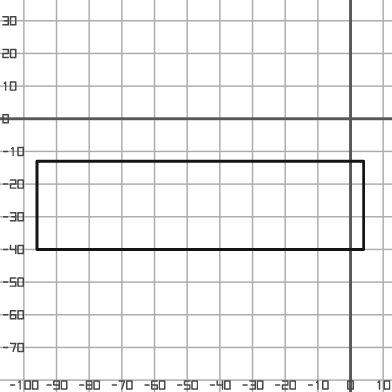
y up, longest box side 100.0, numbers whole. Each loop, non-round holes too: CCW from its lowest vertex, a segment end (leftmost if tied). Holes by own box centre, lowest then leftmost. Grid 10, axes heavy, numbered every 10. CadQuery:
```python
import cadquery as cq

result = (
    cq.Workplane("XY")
    .moveTo(-96.0, -40.0)
    .lineTo(4.0, -40.0)
    .lineTo(4.0, -13.0)
    .lineTo(-96.0, -13.0)
    .close()
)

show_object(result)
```